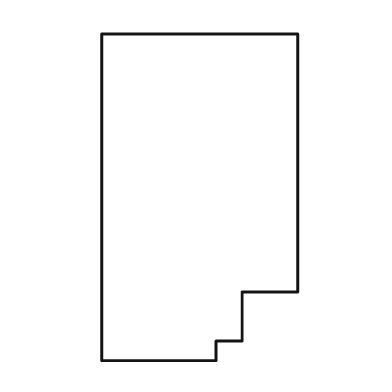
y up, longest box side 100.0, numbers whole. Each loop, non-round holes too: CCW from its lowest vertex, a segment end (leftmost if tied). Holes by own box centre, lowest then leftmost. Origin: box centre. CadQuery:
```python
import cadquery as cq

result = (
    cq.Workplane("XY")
    .moveTo(-30.0, -50.0)
    .lineTo(5.0, -50.0)
    .lineTo(5.0, -44.0)
    .lineTo(13.0, -44.0)
    .lineTo(13.0, -29.0)
    .lineTo(30.0, -29.0)
    .lineTo(30.0, 50.0)
    .lineTo(-30.0, 50.0)
    .close()
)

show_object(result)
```